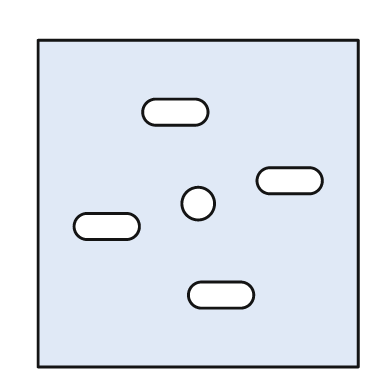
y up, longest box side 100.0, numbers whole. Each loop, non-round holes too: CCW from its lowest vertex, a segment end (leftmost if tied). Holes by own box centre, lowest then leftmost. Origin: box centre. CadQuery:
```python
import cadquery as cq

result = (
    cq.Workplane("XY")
    .moveTo(-49.0, -50.0)
    .lineTo(49.0, -50.0)
    .lineTo(49.0, 50.0)
    .lineTo(-49.0, 50.0)
    .close()
    .moveTo(1.0, -32.0)
    .lineTo(13.0, -32.0)
    .threePointArc((17.0, -28.0), (13.0, -24.0))
    .lineTo(1.0, -24.0)
    .threePointArc((-3.0, -28.0), (1.0, -32.0))
    .close()
    .moveTo(-34.0, -11.0)
    .lineTo(-22.0, -11.0)
    .threePointArc((-18.0, -7.0), (-22.0, -3.0))
    .lineTo(-34.0, -3.0)
    .threePointArc((-38.0, -7.0), (-34.0, -11.0))
    .close()
    .moveTo(0.0, 0.0)
    .circle(5.0)
    .moveTo(22.0, 3.0)
    .lineTo(34.0, 3.0)
    .threePointArc((38.0, 7.0), (34.0, 11.0))
    .lineTo(22.0, 11.0)
    .threePointArc((18.0, 7.0), (22.0, 3.0))
    .close()
    .moveTo(-13.0, 24.0)
    .lineTo(-1.0, 24.0)
    .threePointArc((3.0, 28.0), (-1.0, 32.0))
    .lineTo(-13.0, 32.0)
    .threePointArc((-17.0, 28.0), (-13.0, 24.0))
    .close()
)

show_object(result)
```